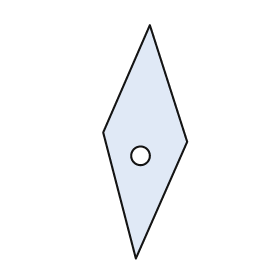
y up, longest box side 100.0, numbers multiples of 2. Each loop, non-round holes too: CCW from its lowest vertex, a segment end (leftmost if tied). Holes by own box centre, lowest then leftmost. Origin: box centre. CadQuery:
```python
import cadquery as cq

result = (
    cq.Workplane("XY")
    .moveTo(-4.0, -50.0)
    .lineTo(18.0, 0.0)
    .lineTo(2.0, 50.0)
    .lineTo(-18.0, 4.0)
    .close()
    .moveTo(-2.0, -6.0)
    .circle(4.0)
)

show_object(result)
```